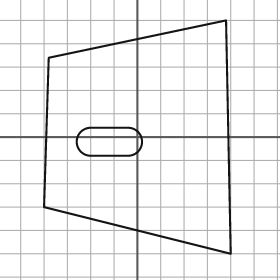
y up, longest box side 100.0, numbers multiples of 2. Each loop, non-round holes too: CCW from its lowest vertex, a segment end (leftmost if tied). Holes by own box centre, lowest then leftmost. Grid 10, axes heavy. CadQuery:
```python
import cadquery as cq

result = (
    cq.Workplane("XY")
    .moveTo(40.0, -50.0)
    .lineTo(38.0, 50.0)
    .lineTo(-38.0, 34.0)
    .lineTo(-40.0, -30.0)
    .close()
    .moveTo(-20.0, -8.0)
    .lineTo(-4.0, -8.0)
    .threePointArc((2.0, -2.0), (-4.0, 4.0))
    .lineTo(-20.0, 4.0)
    .threePointArc((-26.0, -2.0), (-20.0, -8.0))
    .close()
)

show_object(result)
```